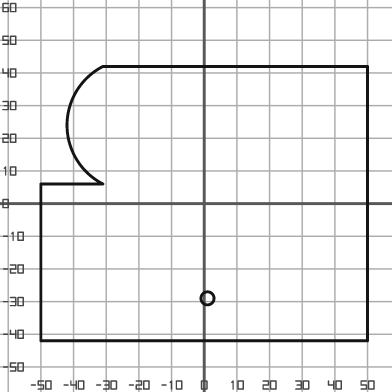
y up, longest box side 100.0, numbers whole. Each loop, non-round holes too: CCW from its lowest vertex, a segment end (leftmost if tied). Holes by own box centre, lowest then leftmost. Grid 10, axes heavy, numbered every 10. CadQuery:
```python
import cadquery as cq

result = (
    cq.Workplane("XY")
    .moveTo(-50.0, -42.0)
    .lineTo(50.0, -42.0)
    .lineTo(50.0, 42.0)
    .lineTo(-31.0, 42.0)
    .threePointArc((-42.0, 24.0), (-31.0, 6.0))
    .lineTo(-50.0, 6.0)
    .close()
    .moveTo(1.0, -29.0)
    .circle(2.0)
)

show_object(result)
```